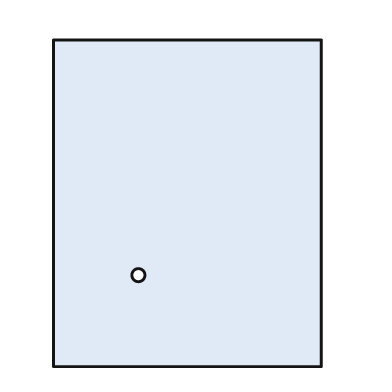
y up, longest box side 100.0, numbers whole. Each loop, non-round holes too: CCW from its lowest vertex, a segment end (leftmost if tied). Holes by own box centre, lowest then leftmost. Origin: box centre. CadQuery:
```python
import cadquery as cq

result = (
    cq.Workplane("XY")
    .moveTo(-41.0, -50.0)
    .lineTo(41.0, -50.0)
    .lineTo(41.0, 50.0)
    .lineTo(-41.0, 50.0)
    .close()
    .moveTo(-15.0, -22.0)
    .circle(2.0)
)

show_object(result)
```